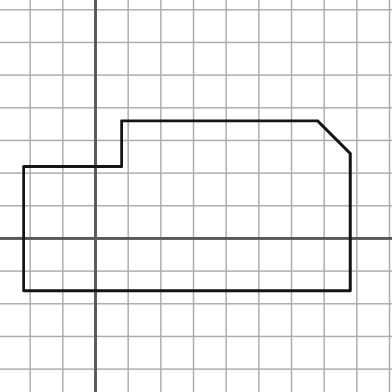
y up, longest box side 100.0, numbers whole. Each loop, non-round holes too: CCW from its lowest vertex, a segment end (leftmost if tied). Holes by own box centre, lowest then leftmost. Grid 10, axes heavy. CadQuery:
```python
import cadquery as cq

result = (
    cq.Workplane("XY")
    .moveTo(-22.0, -16.0)
    .lineTo(78.0, -16.0)
    .lineTo(78.0, 26.0)
    .lineTo(68.0, 36.0)
    .lineTo(8.0, 36.0)
    .lineTo(8.0, 22.0)
    .lineTo(-22.0, 22.0)
    .close()
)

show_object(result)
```